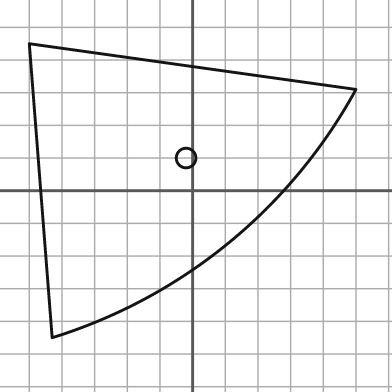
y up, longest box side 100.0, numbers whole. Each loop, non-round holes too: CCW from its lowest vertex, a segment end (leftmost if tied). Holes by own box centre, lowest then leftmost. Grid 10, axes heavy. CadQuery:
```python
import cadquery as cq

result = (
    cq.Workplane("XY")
    .moveTo(-43.0, -45.0)
    .threePointArc((11.0, -16.0), (50.0, 31.0))
    .lineTo(-50.0, 45.0)
    .close()
    .moveTo(-2.0, 10.0)
    .circle(3.0)
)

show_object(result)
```